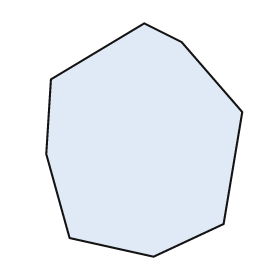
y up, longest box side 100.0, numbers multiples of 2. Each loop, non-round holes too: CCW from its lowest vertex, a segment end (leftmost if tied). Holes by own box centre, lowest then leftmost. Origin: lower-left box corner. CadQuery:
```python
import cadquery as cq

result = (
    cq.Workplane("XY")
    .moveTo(46.0, 0.0)
    .lineTo(76.0, 14.0)
    .lineTo(84.0, 62.0)
    .lineTo(58.0, 92.0)
    .lineTo(42.0, 100.0)
    .lineTo(2.0, 76.0)
    .lineTo(0.0, 44.0)
    .lineTo(10.0, 8.0)
    .close()
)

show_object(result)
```